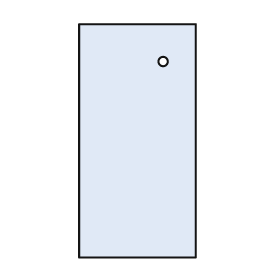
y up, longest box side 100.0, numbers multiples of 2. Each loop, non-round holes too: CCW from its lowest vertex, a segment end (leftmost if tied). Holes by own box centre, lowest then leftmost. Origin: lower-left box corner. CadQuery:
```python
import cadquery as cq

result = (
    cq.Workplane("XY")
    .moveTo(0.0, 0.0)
    .lineTo(50.0, 0.0)
    .lineTo(50.0, 100.0)
    .lineTo(0.0, 100.0)
    .close()
    .moveTo(36.0, 84.0)
    .circle(2.0)
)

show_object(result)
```